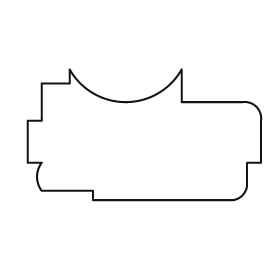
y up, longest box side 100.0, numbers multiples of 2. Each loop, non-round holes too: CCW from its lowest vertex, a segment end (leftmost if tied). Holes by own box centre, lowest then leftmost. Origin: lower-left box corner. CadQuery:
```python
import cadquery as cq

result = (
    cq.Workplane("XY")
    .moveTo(28.0, 0.0)
    .lineTo(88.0, 0.0)
    .threePointArc((92.0, 2.0), (94.0, 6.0))
    .lineTo(94.0, 16.0)
    .lineTo(100.0, 16.0)
    .lineTo(100.0, 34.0)
    .threePointArc((98.0, 40.0), (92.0, 42.0))
    .lineTo(66.0, 42.0)
    .lineTo(66.0, 56.0)
    .threePointArc((42.0, 42.0), (18.0, 56.0))
    .lineTo(18.0, 50.0)
    .lineTo(6.0, 50.0)
    .lineTo(6.0, 34.0)
    .lineTo(0.0, 34.0)
    .lineTo(0.0, 16.0)
    .lineTo(6.0, 16.0)
    .threePointArc((4.0, 10.0), (6.0, 4.0))
    .lineTo(28.0, 4.0)
    .close()
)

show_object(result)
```